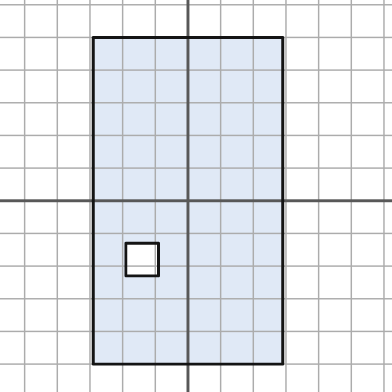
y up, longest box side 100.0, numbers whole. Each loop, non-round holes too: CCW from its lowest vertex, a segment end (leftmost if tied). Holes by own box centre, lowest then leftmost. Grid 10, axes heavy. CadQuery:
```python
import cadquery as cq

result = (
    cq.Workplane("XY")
    .moveTo(-29.0, -50.0)
    .lineTo(29.0, -50.0)
    .lineTo(29.0, 50.0)
    .lineTo(-29.0, 50.0)
    .close()
    .moveTo(-19.0, -23.0)
    .lineTo(-9.0, -23.0)
    .lineTo(-9.0, -13.0)
    .lineTo(-19.0, -13.0)
    .close()
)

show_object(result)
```